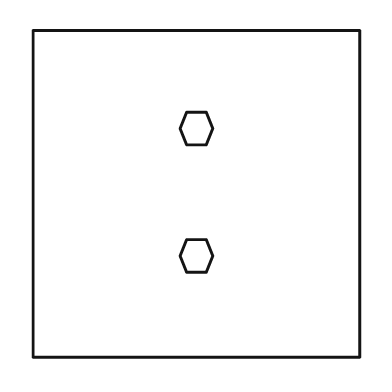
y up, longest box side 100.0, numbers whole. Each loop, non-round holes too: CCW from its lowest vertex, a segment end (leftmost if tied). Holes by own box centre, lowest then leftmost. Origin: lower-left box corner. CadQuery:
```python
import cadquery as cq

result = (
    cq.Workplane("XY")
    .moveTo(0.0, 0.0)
    .lineTo(100.0, 0.0)
    .lineTo(100.0, 100.0)
    .lineTo(0.0, 100.0)
    .close()
    .moveTo(47.0, 26.0)
    .lineTo(53.0, 26.0)
    .lineTo(55.0, 31.0)
    .lineTo(53.0, 36.0)
    .lineTo(47.0, 36.0)
    .lineTo(45.0, 31.0)
    .close()
    .moveTo(47.0, 65.0)
    .lineTo(53.0, 65.0)
    .lineTo(55.0, 70.0)
    .lineTo(53.0, 75.0)
    .lineTo(47.0, 75.0)
    .lineTo(45.0, 70.0)
    .close()
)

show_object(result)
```